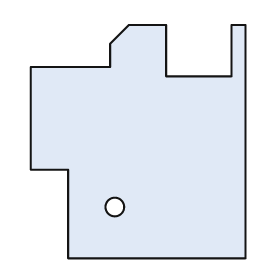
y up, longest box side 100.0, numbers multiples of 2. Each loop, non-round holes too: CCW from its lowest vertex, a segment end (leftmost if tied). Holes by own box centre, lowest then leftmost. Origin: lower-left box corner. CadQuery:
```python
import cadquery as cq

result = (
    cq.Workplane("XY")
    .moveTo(16.0, 0.0)
    .lineTo(92.0, 0.0)
    .lineTo(92.0, 100.0)
    .lineTo(86.0, 100.0)
    .lineTo(86.0, 78.0)
    .lineTo(58.0, 78.0)
    .lineTo(58.0, 100.0)
    .lineTo(42.0, 100.0)
    .lineTo(34.0, 92.0)
    .lineTo(34.0, 82.0)
    .lineTo(0.0, 82.0)
    .lineTo(0.0, 38.0)
    .lineTo(16.0, 38.0)
    .close()
    .moveTo(36.0, 22.0)
    .circle(4.0)
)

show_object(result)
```